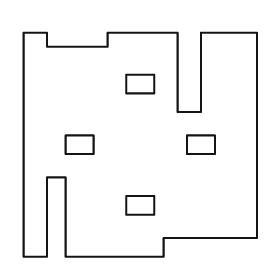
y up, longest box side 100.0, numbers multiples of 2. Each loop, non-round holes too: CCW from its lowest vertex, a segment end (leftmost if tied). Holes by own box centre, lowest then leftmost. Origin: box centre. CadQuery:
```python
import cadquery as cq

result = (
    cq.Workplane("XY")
    .moveTo(-50.0, -48.0)
    .lineTo(-40.0, -48.0)
    .lineTo(-40.0, -14.0)
    .lineTo(-32.0, -14.0)
    .lineTo(-32.0, -48.0)
    .lineTo(10.0, -48.0)
    .lineTo(10.0, -40.0)
    .lineTo(50.0, -40.0)
    .lineTo(50.0, 48.0)
    .lineTo(26.0, 48.0)
    .lineTo(26.0, 14.0)
    .lineTo(16.0, 14.0)
    .lineTo(16.0, 48.0)
    .lineTo(-14.0, 48.0)
    .lineTo(-14.0, 42.0)
    .lineTo(-40.0, 42.0)
    .lineTo(-40.0, 48.0)
    .lineTo(-50.0, 48.0)
    .close()
    .moveTo(-6.0, -30.0)
    .lineTo(6.0, -30.0)
    .lineTo(6.0, -22.0)
    .lineTo(-6.0, -22.0)
    .close()
    .moveTo(-32.0, -4.0)
    .lineTo(-20.0, -4.0)
    .lineTo(-20.0, 4.0)
    .lineTo(-32.0, 4.0)
    .close()
    .moveTo(20.0, -4.0)
    .lineTo(32.0, -4.0)
    .lineTo(32.0, 4.0)
    .lineTo(20.0, 4.0)
    .close()
    .moveTo(-6.0, 22.0)
    .lineTo(6.0, 22.0)
    .lineTo(6.0, 30.0)
    .lineTo(-6.0, 30.0)
    .close()
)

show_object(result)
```